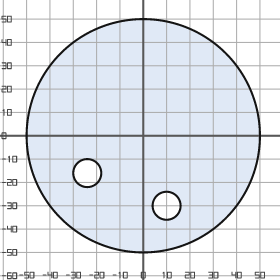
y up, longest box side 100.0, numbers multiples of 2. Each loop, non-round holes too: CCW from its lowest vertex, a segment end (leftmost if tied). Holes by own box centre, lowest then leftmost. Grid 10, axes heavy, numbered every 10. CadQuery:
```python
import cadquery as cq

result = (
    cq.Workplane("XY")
    .moveTo(0.0, 0.0)
    .circle(50.0)
    .moveTo(10.0, -30.0)
    .circle(6.0)
    .moveTo(-24.0, -16.0)
    .circle(6.0)
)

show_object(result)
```